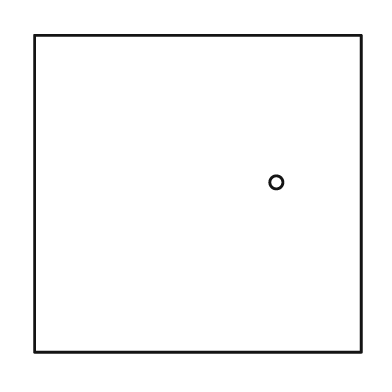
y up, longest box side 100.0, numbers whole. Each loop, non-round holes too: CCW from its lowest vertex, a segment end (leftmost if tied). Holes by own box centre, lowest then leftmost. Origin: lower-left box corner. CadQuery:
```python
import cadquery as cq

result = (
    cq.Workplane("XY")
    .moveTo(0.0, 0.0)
    .lineTo(100.0, 0.0)
    .lineTo(100.0, 97.0)
    .lineTo(0.0, 97.0)
    .close()
    .moveTo(74.0, 52.0)
    .circle(2.0)
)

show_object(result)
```